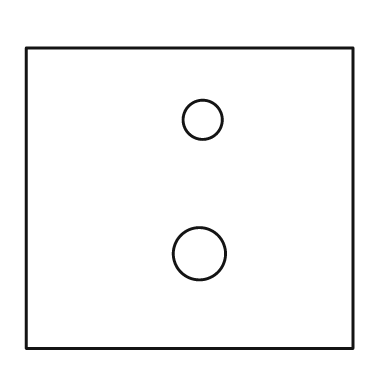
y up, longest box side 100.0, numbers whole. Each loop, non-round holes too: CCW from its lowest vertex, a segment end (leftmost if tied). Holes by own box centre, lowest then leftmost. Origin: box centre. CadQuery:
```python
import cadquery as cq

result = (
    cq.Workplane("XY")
    .moveTo(-50.0, -46.0)
    .lineTo(50.0, -46.0)
    .lineTo(50.0, 46.0)
    .lineTo(-50.0, 46.0)
    .close()
    .moveTo(3.0, -17.0)
    .circle(8.0)
    .moveTo(4.0, 24.0)
    .circle(6.0)
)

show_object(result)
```